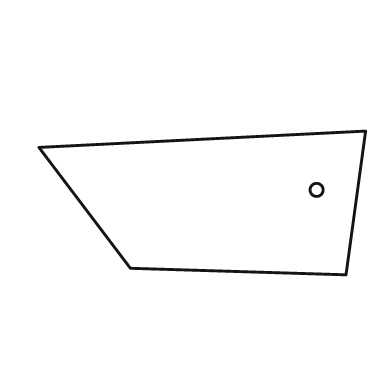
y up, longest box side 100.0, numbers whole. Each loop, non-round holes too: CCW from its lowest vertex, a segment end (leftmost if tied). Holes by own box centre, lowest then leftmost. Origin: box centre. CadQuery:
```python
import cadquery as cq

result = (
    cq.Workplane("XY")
    .moveTo(44.0, -22.0)
    .lineTo(50.0, 22.0)
    .lineTo(-50.0, 17.0)
    .lineTo(-22.0, -20.0)
    .close()
    .moveTo(35.0, 4.0)
    .circle(2.0)
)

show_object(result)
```